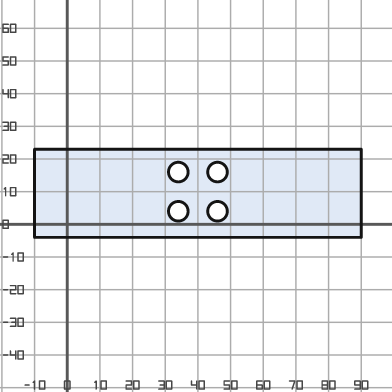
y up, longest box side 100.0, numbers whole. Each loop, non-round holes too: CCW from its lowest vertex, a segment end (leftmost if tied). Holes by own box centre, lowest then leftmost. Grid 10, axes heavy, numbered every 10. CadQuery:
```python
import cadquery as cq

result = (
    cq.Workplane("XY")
    .moveTo(-10.0, -4.0)
    .lineTo(90.0, -4.0)
    .lineTo(90.0, 23.0)
    .lineTo(-10.0, 23.0)
    .close()
    .moveTo(34.0, 4.0)
    .circle(3.0)
    .moveTo(46.0, 4.0)
    .circle(3.0)
    .moveTo(34.0, 16.0)
    .circle(3.0)
    .moveTo(46.0, 16.0)
    .circle(3.0)
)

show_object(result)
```